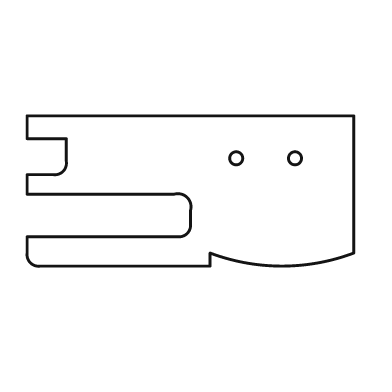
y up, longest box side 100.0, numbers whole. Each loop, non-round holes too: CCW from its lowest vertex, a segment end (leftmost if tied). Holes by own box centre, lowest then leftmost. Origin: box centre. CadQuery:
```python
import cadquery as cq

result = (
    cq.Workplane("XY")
    .moveTo(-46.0, -23.0)
    .lineTo(6.0, -23.0)
    .lineTo(6.0, -19.0)
    .threePointArc((28.0, -23.0), (50.0, -19.0))
    .lineTo(50.0, 23.0)
    .lineTo(-50.0, 23.0)
    .lineTo(-50.0, 16.0)
    .lineTo(-38.0, 16.0)
    .lineTo(-38.0, 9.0)
    .threePointArc((-39.0, 6.0), (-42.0, 5.0))
    .lineTo(-50.0, 5.0)
    .lineTo(-50.0, -1.0)
    .lineTo(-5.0, -1.0)
    .threePointArc((-1.0, -2.0), (0.0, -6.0))
    .lineTo(0.0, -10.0)
    .threePointArc((-1.0, -13.0), (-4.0, -14.0))
    .lineTo(-50.0, -14.0)
    .lineTo(-50.0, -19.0)
    .threePointArc((-49.0, -22.0), (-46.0, -23.0))
    .close()
    .moveTo(14.0, 10.0)
    .circle(2.0)
    .moveTo(32.0, 10.0)
    .circle(2.0)
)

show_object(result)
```